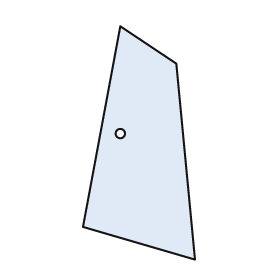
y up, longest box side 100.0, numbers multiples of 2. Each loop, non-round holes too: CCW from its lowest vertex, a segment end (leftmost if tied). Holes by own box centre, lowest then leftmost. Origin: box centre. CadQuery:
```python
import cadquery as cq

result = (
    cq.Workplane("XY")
    .moveTo(24.0, -50.0)
    .lineTo(16.0, 34.0)
    .lineTo(-8.0, 50.0)
    .lineTo(-24.0, -36.0)
    .close()
    .moveTo(-8.0, 4.0)
    .circle(2.0)
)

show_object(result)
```